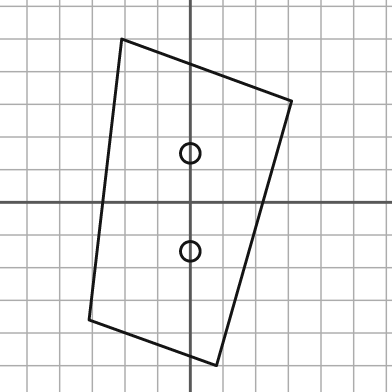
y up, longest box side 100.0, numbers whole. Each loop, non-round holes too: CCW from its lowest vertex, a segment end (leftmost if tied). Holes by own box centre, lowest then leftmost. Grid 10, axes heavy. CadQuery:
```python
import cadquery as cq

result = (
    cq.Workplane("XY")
    .moveTo(8.0, -50.0)
    .lineTo(31.0, 31.0)
    .lineTo(-21.0, 50.0)
    .lineTo(-31.0, -36.0)
    .close()
    .moveTo(0.0, -15.0)
    .circle(3.0)
    .moveTo(0.0, 15.0)
    .circle(3.0)
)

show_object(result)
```